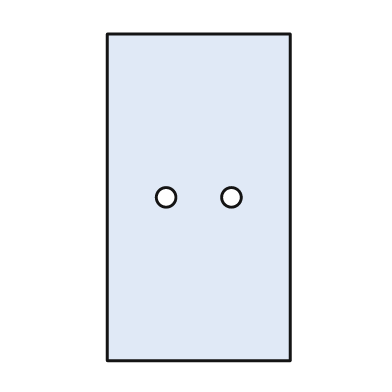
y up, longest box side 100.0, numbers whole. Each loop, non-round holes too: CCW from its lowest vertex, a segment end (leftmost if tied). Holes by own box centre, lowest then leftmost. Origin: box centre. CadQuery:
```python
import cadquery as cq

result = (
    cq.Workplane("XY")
    .moveTo(-28.0, -50.0)
    .lineTo(28.0, -50.0)
    .lineTo(28.0, 50.0)
    .lineTo(-28.0, 50.0)
    .close()
    .moveTo(-10.0, 0.0)
    .circle(3.0)
    .moveTo(10.0, 0.0)
    .circle(3.0)
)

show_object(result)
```